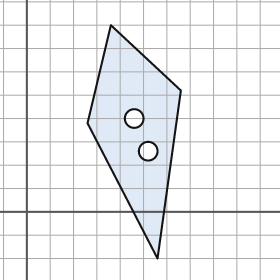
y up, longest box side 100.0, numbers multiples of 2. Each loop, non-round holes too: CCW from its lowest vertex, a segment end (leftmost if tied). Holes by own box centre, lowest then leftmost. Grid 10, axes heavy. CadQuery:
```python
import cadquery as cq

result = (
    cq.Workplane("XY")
    .moveTo(56.0, -20.0)
    .lineTo(66.0, 52.0)
    .lineTo(36.0, 80.0)
    .lineTo(26.0, 38.0)
    .close()
    .moveTo(52.0, 26.0)
    .circle(4.0)
    .moveTo(46.0, 40.0)
    .circle(4.0)
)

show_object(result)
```